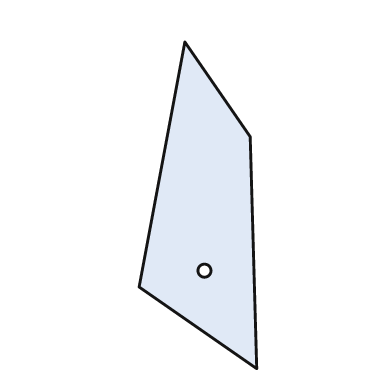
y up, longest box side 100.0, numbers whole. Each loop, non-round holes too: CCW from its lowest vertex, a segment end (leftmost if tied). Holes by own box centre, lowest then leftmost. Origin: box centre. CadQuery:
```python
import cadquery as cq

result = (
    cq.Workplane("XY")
    .moveTo(18.0, -50.0)
    .lineTo(16.0, 21.0)
    .lineTo(-4.0, 50.0)
    .lineTo(-18.0, -25.0)
    .close()
    .moveTo(2.0, -20.0)
    .circle(2.0)
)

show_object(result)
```